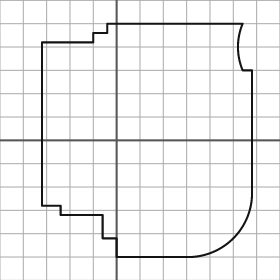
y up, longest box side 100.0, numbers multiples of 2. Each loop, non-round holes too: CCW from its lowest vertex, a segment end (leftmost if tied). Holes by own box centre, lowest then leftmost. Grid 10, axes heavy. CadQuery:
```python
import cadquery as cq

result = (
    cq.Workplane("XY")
    .moveTo(0.0, -50.0)
    .lineTo(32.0, -50.0)
    .threePointArc((50.0, -42.0), (58.0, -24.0))
    .lineTo(58.0, 30.0)
    .lineTo(54.0, 30.0)
    .threePointArc((52.0, 40.0), (54.0, 50.0))
    .lineTo(-4.0, 50.0)
    .lineTo(-4.0, 46.0)
    .lineTo(-10.0, 46.0)
    .lineTo(-10.0, 42.0)
    .lineTo(-32.0, 42.0)
    .lineTo(-32.0, -28.0)
    .lineTo(-24.0, -28.0)
    .lineTo(-24.0, -32.0)
    .lineTo(-6.0, -32.0)
    .lineTo(-6.0, -42.0)
    .lineTo(0.0, -42.0)
    .close()
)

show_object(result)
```